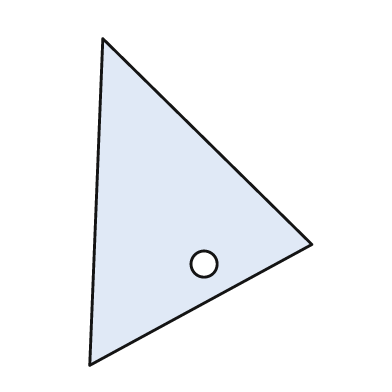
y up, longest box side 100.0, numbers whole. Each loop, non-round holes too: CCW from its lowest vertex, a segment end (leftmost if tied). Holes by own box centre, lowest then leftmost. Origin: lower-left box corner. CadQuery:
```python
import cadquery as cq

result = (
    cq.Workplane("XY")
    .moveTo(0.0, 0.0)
    .lineTo(68.0, 37.0)
    .lineTo(4.0, 100.0)
    .close()
    .moveTo(35.0, 31.0)
    .circle(4.0)
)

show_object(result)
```